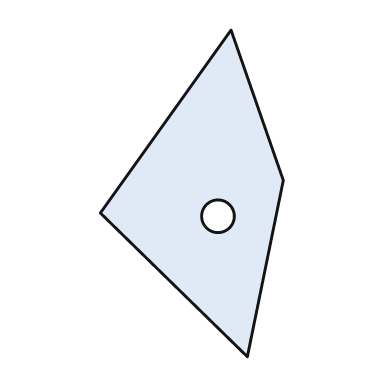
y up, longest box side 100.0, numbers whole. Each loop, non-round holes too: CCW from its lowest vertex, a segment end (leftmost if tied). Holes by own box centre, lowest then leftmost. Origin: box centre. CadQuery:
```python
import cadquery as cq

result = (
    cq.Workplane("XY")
    .moveTo(17.0, -50.0)
    .lineTo(28.0, 4.0)
    .lineTo(12.0, 50.0)
    .lineTo(-28.0, -6.0)
    .close()
    .moveTo(8.0, -7.0)
    .circle(5.0)
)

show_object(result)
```